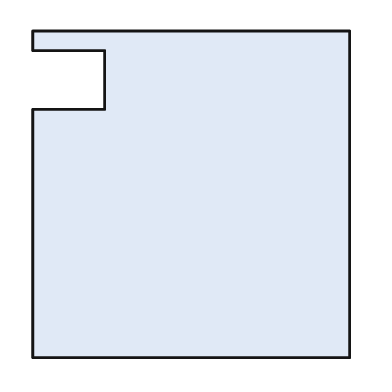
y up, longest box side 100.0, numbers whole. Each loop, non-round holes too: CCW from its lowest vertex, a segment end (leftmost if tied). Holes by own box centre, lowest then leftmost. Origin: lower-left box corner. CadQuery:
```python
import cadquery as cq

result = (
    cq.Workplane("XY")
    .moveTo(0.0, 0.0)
    .lineTo(97.0, 0.0)
    .lineTo(97.0, 100.0)
    .lineTo(0.0, 100.0)
    .lineTo(0.0, 94.0)
    .lineTo(22.0, 94.0)
    .lineTo(22.0, 76.0)
    .lineTo(0.0, 76.0)
    .close()
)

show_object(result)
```